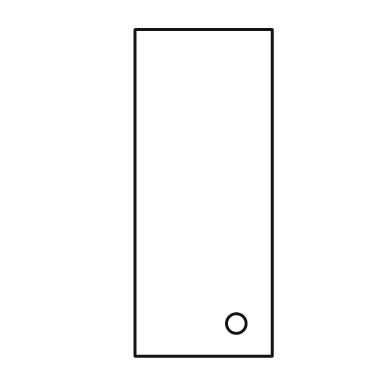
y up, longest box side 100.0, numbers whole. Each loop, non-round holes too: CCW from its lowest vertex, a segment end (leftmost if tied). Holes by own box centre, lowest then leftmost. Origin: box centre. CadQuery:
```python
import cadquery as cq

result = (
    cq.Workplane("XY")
    .moveTo(-21.0, -50.0)
    .lineTo(21.0, -50.0)
    .lineTo(21.0, 50.0)
    .lineTo(-21.0, 50.0)
    .close()
    .moveTo(10.0, -40.0)
    .circle(3.0)
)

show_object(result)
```